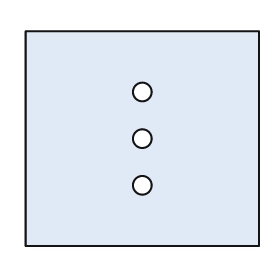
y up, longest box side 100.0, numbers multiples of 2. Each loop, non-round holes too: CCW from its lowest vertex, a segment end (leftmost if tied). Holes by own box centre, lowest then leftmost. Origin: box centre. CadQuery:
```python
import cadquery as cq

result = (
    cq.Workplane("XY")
    .moveTo(-50.0, -46.0)
    .lineTo(50.0, -46.0)
    .lineTo(50.0, 46.0)
    .lineTo(-50.0, 46.0)
    .close()
    .moveTo(0.0, -20.0)
    .circle(4.0)
    .moveTo(0.0, 0.0)
    .circle(4.0)
    .moveTo(0.0, 20.0)
    .circle(4.0)
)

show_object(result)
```